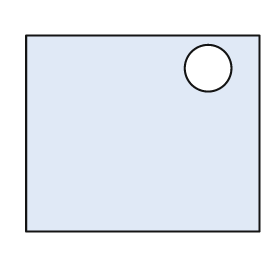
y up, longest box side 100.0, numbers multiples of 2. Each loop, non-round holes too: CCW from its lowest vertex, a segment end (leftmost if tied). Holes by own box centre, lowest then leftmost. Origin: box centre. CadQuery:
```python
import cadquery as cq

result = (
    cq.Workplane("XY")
    .moveTo(-50.0, -42.0)
    .lineTo(50.0, -42.0)
    .lineTo(50.0, 42.0)
    .lineTo(-50.0, 42.0)
    .close()
    .moveTo(28.0, 28.0)
    .circle(10.0)
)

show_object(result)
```